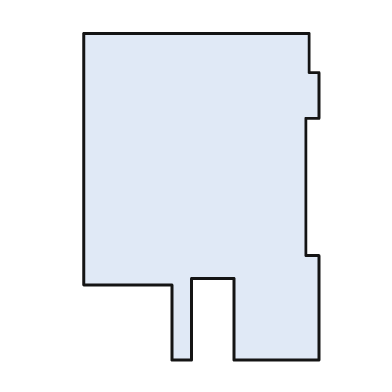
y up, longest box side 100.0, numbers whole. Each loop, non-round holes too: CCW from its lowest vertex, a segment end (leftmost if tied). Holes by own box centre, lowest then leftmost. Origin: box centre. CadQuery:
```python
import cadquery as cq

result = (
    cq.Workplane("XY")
    .moveTo(-9.0, -50.0)
    .lineTo(-3.0, -50.0)
    .lineTo(-3.0, -25.0)
    .lineTo(10.0, -25.0)
    .lineTo(10.0, -50.0)
    .lineTo(36.0, -50.0)
    .lineTo(36.0, -18.0)
    .lineTo(32.0, -18.0)
    .lineTo(32.0, 24.0)
    .lineTo(36.0, 24.0)
    .lineTo(36.0, 38.0)
    .lineTo(33.0, 38.0)
    .lineTo(33.0, 50.0)
    .lineTo(-36.0, 50.0)
    .lineTo(-36.0, -27.0)
    .lineTo(-9.0, -27.0)
    .close()
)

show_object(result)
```